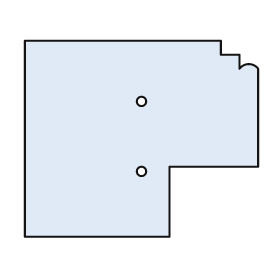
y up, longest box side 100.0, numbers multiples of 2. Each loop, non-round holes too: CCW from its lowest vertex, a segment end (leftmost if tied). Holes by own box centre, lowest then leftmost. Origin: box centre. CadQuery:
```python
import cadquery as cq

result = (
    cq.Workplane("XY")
    .moveTo(-50.0, -42.0)
    .lineTo(12.0, -42.0)
    .lineTo(12.0, -12.0)
    .lineTo(50.0, -12.0)
    .lineTo(50.0, 30.0)
    .threePointArc((46.0, 32.0), (42.0, 30.0))
    .lineTo(42.0, 36.0)
    .lineTo(34.0, 36.0)
    .lineTo(34.0, 42.0)
    .lineTo(-50.0, 42.0)
    .close()
    .moveTo(0.0, -14.0)
    .circle(2.0)
    .moveTo(0.0, 16.0)
    .circle(2.0)
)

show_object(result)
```